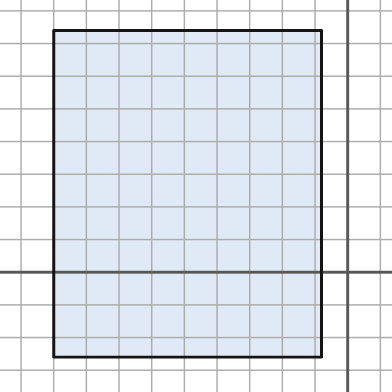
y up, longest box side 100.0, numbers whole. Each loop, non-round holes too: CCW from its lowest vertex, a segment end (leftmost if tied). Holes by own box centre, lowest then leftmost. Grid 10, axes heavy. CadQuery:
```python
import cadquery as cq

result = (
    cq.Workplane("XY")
    .moveTo(-90.0, -26.0)
    .lineTo(-8.0, -26.0)
    .lineTo(-8.0, 74.0)
    .lineTo(-90.0, 74.0)
    .close()
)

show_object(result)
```